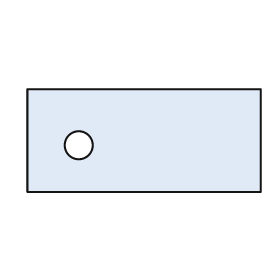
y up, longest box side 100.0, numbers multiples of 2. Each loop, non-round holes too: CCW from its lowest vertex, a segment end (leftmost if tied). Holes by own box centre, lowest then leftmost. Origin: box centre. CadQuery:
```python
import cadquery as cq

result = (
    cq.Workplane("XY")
    .moveTo(-50.0, -22.0)
    .lineTo(50.0, -22.0)
    .lineTo(50.0, 22.0)
    .lineTo(-50.0, 22.0)
    .close()
    .moveTo(-28.0, -2.0)
    .circle(6.0)
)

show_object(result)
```